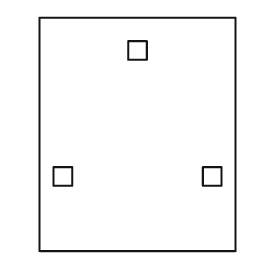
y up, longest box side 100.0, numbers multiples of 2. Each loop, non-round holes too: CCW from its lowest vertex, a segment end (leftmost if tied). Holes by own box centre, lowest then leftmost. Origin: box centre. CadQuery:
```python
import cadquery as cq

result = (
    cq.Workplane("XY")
    .moveTo(-42.0, -50.0)
    .lineTo(42.0, -50.0)
    .lineTo(42.0, 50.0)
    .lineTo(-42.0, 50.0)
    .close()
    .moveTo(-36.0, -22.0)
    .lineTo(-28.0, -22.0)
    .lineTo(-28.0, -14.0)
    .lineTo(-36.0, -14.0)
    .close()
    .moveTo(28.0, -22.0)
    .lineTo(36.0, -22.0)
    .lineTo(36.0, -14.0)
    .lineTo(28.0, -14.0)
    .close()
    .moveTo(-4.0, 32.0)
    .lineTo(4.0, 32.0)
    .lineTo(4.0, 40.0)
    .lineTo(-4.0, 40.0)
    .close()
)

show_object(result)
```